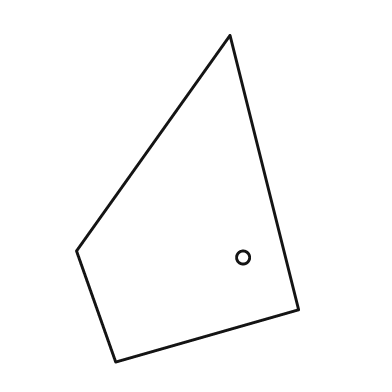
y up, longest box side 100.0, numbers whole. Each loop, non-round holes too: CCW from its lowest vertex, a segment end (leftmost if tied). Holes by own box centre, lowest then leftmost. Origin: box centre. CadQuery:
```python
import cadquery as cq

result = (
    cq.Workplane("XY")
    .moveTo(-22.0, -50.0)
    .lineTo(34.0, -34.0)
    .lineTo(13.0, 50.0)
    .lineTo(-34.0, -16.0)
    .close()
    .moveTo(17.0, -18.0)
    .circle(2.0)
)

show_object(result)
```